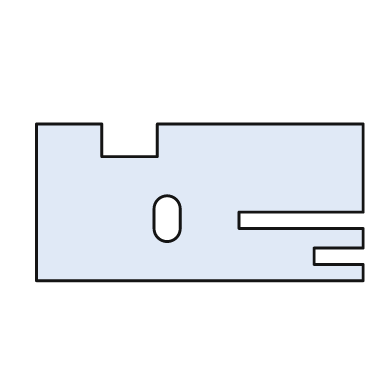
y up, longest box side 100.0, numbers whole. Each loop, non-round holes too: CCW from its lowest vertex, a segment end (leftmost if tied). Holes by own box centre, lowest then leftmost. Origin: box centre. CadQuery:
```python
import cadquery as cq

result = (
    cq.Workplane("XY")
    .moveTo(-50.0, -24.0)
    .lineTo(50.0, -24.0)
    .lineTo(50.0, -19.0)
    .lineTo(35.0, -19.0)
    .lineTo(35.0, -14.0)
    .lineTo(50.0, -14.0)
    .lineTo(50.0, -8.0)
    .lineTo(12.0, -8.0)
    .lineTo(12.0, -3.0)
    .lineTo(50.0, -3.0)
    .lineTo(50.0, 24.0)
    .lineTo(-13.0, 24.0)
    .lineTo(-13.0, 14.0)
    .lineTo(-30.0, 14.0)
    .lineTo(-30.0, 24.0)
    .lineTo(-50.0, 24.0)
    .close()
    .moveTo(-14.0, -8.0)
    .threePointArc((-10.0, -12.0), (-6.0, -8.0))
    .lineTo(-6.0, -2.0)
    .threePointArc((-10.0, 2.0), (-14.0, -2.0))
    .close()
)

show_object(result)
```